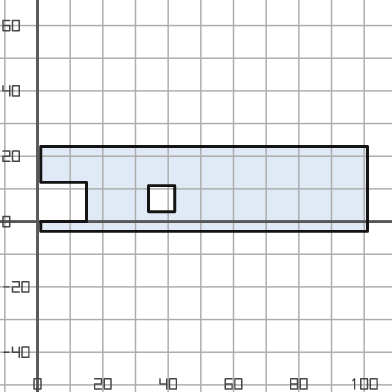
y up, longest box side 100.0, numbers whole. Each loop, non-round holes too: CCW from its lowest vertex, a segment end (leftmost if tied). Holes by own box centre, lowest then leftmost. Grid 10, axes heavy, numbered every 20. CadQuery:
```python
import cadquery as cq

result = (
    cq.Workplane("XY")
    .moveTo(1.0, -3.0)
    .lineTo(101.0, -3.0)
    .lineTo(101.0, 23.0)
    .lineTo(1.0, 23.0)
    .lineTo(1.0, 12.0)
    .lineTo(15.0, 12.0)
    .lineTo(15.0, 0.0)
    .lineTo(1.0, 0.0)
    .close()
    .moveTo(34.0, 3.0)
    .lineTo(42.0, 3.0)
    .lineTo(42.0, 11.0)
    .lineTo(34.0, 11.0)
    .close()
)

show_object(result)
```